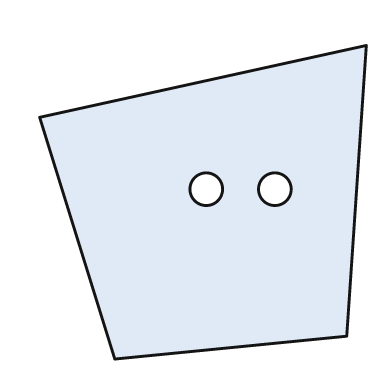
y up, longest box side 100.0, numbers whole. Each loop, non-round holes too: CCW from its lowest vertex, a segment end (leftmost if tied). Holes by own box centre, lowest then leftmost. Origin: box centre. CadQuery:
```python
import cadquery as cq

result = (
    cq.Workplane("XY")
    .moveTo(-27.0, -48.0)
    .lineTo(44.0, -41.0)
    .lineTo(50.0, 48.0)
    .lineTo(-50.0, 26.0)
    .close()
    .moveTo(1.0, 4.0)
    .circle(5.0)
    .moveTo(22.0, 4.0)
    .circle(5.0)
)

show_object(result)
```